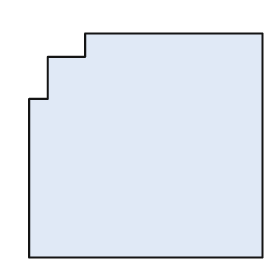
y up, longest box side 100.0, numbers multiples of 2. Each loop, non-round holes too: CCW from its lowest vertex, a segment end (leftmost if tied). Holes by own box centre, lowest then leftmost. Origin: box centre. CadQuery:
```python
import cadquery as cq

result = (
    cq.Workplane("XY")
    .moveTo(-50.0, -48.0)
    .lineTo(50.0, -48.0)
    .lineTo(50.0, 48.0)
    .lineTo(-26.0, 48.0)
    .lineTo(-26.0, 38.0)
    .lineTo(-42.0, 38.0)
    .lineTo(-42.0, 20.0)
    .lineTo(-50.0, 20.0)
    .close()
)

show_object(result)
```